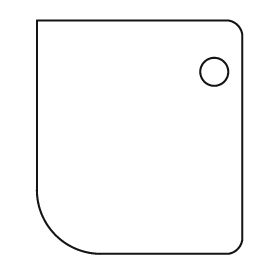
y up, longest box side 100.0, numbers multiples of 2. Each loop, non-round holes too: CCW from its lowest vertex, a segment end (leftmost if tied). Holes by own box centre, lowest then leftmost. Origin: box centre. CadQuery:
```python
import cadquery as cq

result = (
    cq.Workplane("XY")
    .moveTo(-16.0, -50.0)
    .lineTo(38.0, -50.0)
    .threePointArc((42.0, -48.0), (44.0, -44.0))
    .lineTo(44.0, 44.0)
    .threePointArc((42.0, 48.0), (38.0, 50.0))
    .lineTo(-44.0, 50.0)
    .lineTo(-44.0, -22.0)
    .threePointArc((-36.0, -42.0), (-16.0, -50.0))
    .close()
    .moveTo(32.0, 28.0)
    .circle(6.0)
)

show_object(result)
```